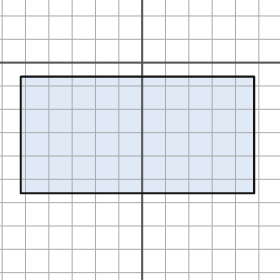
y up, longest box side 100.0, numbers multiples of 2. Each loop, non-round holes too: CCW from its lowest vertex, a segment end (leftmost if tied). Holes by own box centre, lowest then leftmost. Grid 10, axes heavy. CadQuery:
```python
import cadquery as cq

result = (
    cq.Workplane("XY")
    .moveTo(-52.0, -56.0)
    .lineTo(48.0, -56.0)
    .lineTo(48.0, -6.0)
    .lineTo(-52.0, -6.0)
    .close()
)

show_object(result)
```